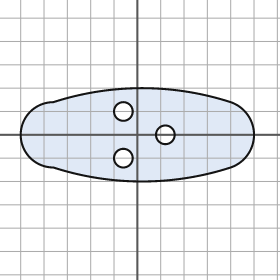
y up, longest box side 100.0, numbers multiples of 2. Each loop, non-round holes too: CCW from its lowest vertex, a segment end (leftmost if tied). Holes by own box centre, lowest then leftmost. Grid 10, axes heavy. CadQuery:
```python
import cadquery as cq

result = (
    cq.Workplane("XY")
    .moveTo(-36.0, -14.0)
    .threePointArc((2.0, -20.0), (40.0, -14.0))
    .threePointArc((50.0, 0.0), (40.0, 14.0))
    .threePointArc((2.0, 20.0), (-36.0, 14.0))
    .threePointArc((-50.0, 0.0), (-36.0, -14.0))
    .close()
    .moveTo(-6.0, -10.0)
    .circle(4.0)
    .moveTo(12.0, 0.0)
    .circle(4.0)
    .moveTo(-6.0, 10.0)
    .circle(4.0)
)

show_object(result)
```